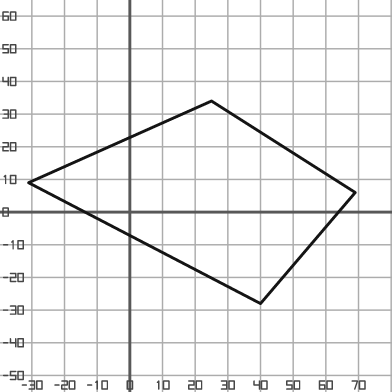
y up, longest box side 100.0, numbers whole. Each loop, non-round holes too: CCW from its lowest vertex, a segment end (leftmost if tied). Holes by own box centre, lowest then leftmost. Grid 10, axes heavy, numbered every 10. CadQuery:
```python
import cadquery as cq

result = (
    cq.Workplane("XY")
    .moveTo(40.0, -28.0)
    .lineTo(69.0, 6.0)
    .lineTo(25.0, 34.0)
    .lineTo(-31.0, 9.0)
    .close()
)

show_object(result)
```